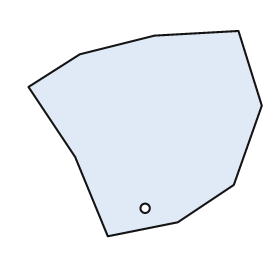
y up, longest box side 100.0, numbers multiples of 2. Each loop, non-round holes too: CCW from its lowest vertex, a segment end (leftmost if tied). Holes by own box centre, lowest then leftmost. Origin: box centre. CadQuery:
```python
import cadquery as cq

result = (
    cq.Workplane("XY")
    .moveTo(-16.0, -44.0)
    .lineTo(14.0, -38.0)
    .lineTo(38.0, -22.0)
    .lineTo(50.0, 12.0)
    .lineTo(40.0, 44.0)
    .lineTo(4.0, 42.0)
    .lineTo(-28.0, 34.0)
    .lineTo(-50.0, 20.0)
    .lineTo(-30.0, -10.0)
    .close()
    .moveTo(0.0, -32.0)
    .circle(2.0)
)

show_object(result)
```